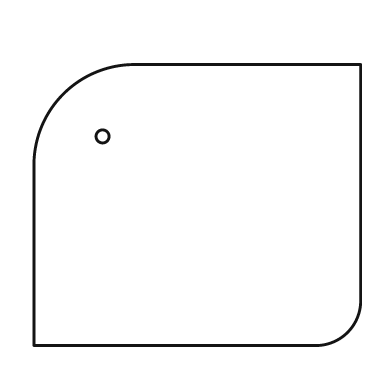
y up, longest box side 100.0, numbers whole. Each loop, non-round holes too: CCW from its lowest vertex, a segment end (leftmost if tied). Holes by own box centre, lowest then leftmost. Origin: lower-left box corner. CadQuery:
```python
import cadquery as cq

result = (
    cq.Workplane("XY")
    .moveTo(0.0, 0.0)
    .lineTo(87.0, 0.0)
    .threePointArc((96.0, 4.0), (100.0, 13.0))
    .lineTo(100.0, 86.0)
    .lineTo(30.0, 86.0)
    .threePointArc((9.0, 77.0), (0.0, 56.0))
    .close()
    .moveTo(21.0, 64.0)
    .circle(2.0)
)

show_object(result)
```